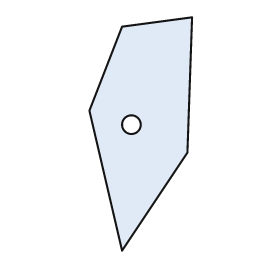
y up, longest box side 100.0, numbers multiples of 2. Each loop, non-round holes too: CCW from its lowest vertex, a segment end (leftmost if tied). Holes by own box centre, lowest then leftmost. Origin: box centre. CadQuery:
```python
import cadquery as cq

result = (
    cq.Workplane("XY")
    .moveTo(-8.0, -50.0)
    .lineTo(20.0, -8.0)
    .lineTo(22.0, 50.0)
    .lineTo(-8.0, 46.0)
    .lineTo(-22.0, 10.0)
    .close()
    .moveTo(-4.0, 4.0)
    .circle(4.0)
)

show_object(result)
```